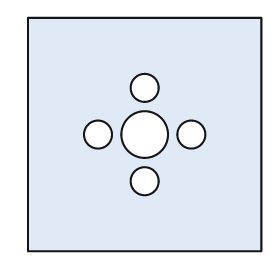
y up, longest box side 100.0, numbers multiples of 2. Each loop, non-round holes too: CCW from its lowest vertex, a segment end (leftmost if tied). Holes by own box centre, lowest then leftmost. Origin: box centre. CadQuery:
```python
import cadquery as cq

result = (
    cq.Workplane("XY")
    .moveTo(-50.0, -50.0)
    .lineTo(50.0, -50.0)
    .lineTo(50.0, 50.0)
    .lineTo(-50.0, 50.0)
    .close()
    .moveTo(0.0, -20.0)
    .circle(6.0)
    .moveTo(-20.0, 0.0)
    .circle(6.0)
    .moveTo(0.0, 0.0)
    .circle(10.0)
    .moveTo(20.0, 0.0)
    .circle(6.0)
    .moveTo(0.0, 20.0)
    .circle(6.0)
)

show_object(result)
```